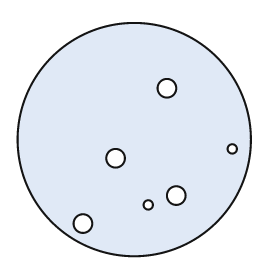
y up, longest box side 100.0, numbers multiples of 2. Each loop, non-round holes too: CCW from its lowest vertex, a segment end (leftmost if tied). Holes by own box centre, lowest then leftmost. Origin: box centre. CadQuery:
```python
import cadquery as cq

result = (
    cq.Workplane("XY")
    .moveTo(0.0, 0.0)
    .circle(50.0)
    .moveTo(-22.0, -36.0)
    .circle(4.0)
    .moveTo(6.0, -28.0)
    .circle(2.0)
    .moveTo(18.0, -24.0)
    .circle(4.0)
    .moveTo(-8.0, -8.0)
    .circle(4.0)
    .moveTo(42.0, -4.0)
    .circle(2.0)
    .moveTo(14.0, 22.0)
    .circle(4.0)
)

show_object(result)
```